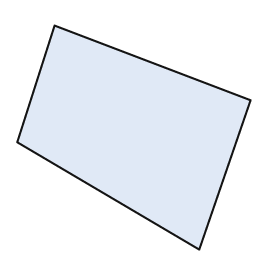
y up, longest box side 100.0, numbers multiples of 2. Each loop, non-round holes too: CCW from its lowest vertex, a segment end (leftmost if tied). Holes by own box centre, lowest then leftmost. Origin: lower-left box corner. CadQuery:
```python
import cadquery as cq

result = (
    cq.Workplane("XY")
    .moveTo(78.0, 0.0)
    .lineTo(100.0, 64.0)
    .lineTo(16.0, 96.0)
    .lineTo(0.0, 46.0)
    .close()
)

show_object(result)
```